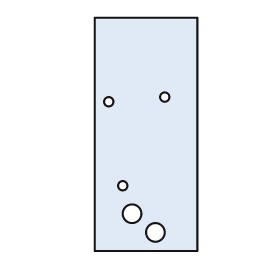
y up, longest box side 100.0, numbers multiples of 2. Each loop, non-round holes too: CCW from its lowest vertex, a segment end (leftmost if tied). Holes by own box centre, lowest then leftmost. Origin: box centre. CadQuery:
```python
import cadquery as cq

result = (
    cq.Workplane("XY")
    .moveTo(-22.0, -50.0)
    .lineTo(22.0, -50.0)
    .lineTo(22.0, 50.0)
    .lineTo(-22.0, 50.0)
    .close()
    .moveTo(4.0, -42.0)
    .circle(4.0)
    .moveTo(-6.0, -34.0)
    .circle(4.0)
    .moveTo(-10.0, -22.0)
    .circle(2.0)
    .moveTo(-16.0, 14.0)
    .circle(2.0)
    .moveTo(8.0, 16.0)
    .circle(2.0)
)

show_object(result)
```